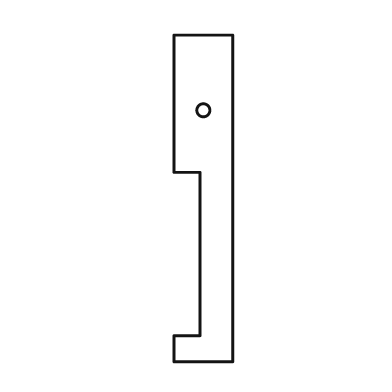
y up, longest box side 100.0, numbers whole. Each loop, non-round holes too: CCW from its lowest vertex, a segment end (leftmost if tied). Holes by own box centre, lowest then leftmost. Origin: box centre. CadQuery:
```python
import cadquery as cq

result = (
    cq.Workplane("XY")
    .moveTo(-9.0, -50.0)
    .lineTo(9.0, -50.0)
    .lineTo(9.0, 50.0)
    .lineTo(-9.0, 50.0)
    .lineTo(-9.0, 8.0)
    .lineTo(-1.0, 8.0)
    .lineTo(-1.0, -42.0)
    .lineTo(-9.0, -42.0)
    .close()
    .moveTo(0.0, 27.0)
    .circle(2.0)
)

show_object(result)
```